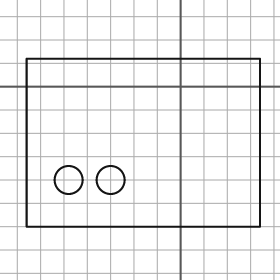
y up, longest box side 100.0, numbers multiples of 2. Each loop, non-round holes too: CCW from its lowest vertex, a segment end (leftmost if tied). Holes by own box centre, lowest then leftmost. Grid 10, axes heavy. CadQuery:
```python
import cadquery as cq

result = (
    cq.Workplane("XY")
    .moveTo(-66.0, -60.0)
    .lineTo(34.0, -60.0)
    .lineTo(34.0, 12.0)
    .lineTo(-66.0, 12.0)
    .close()
    .moveTo(-48.0, -40.0)
    .circle(6.0)
    .moveTo(-30.0, -40.0)
    .circle(6.0)
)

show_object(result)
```